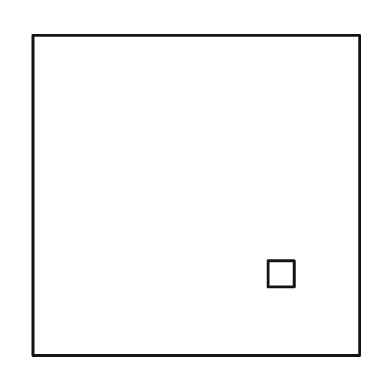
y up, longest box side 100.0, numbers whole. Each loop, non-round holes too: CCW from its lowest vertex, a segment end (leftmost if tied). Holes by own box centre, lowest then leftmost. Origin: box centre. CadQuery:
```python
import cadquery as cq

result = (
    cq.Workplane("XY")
    .moveTo(-50.0, -49.0)
    .lineTo(50.0, -49.0)
    .lineTo(50.0, 49.0)
    .lineTo(-50.0, 49.0)
    .close()
    .moveTo(22.0, -28.0)
    .lineTo(30.0, -28.0)
    .lineTo(30.0, -20.0)
    .lineTo(22.0, -20.0)
    .close()
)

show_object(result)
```